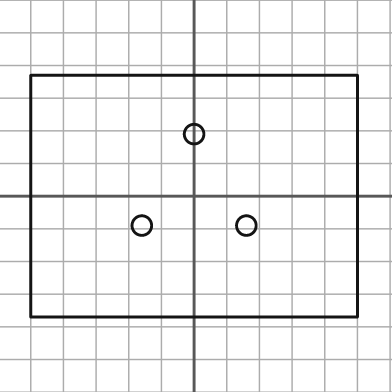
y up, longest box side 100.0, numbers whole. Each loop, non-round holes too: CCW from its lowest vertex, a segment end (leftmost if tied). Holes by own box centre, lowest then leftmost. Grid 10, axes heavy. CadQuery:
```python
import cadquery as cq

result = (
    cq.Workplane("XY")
    .moveTo(-50.0, -37.0)
    .lineTo(50.0, -37.0)
    .lineTo(50.0, 37.0)
    .lineTo(-50.0, 37.0)
    .close()
    .moveTo(-16.0, -9.0)
    .circle(3.0)
    .moveTo(16.0, -9.0)
    .circle(3.0)
    .moveTo(0.0, 19.0)
    .circle(3.0)
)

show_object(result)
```